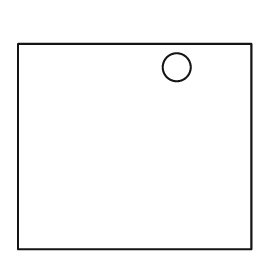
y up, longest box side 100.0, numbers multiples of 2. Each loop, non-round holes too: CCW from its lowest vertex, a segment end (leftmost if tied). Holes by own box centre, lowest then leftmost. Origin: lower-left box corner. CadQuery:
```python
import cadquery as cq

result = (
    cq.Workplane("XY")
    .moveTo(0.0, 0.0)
    .lineTo(100.0, 0.0)
    .lineTo(100.0, 88.0)
    .lineTo(0.0, 88.0)
    .close()
    .moveTo(68.0, 78.0)
    .circle(6.0)
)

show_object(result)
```